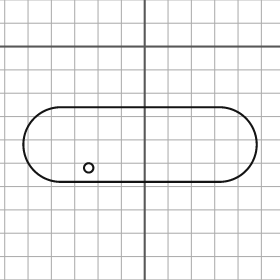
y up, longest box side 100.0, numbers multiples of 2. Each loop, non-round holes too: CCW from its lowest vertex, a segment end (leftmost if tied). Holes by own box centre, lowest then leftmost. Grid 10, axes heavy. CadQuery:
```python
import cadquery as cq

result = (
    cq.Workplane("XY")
    .moveTo(-36.0, -58.0)
    .lineTo(32.0, -58.0)
    .threePointArc((48.0, -42.0), (32.0, -26.0))
    .lineTo(-36.0, -26.0)
    .threePointArc((-52.0, -42.0), (-36.0, -58.0))
    .close()
    .moveTo(-24.0, -52.0)
    .circle(2.0)
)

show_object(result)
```